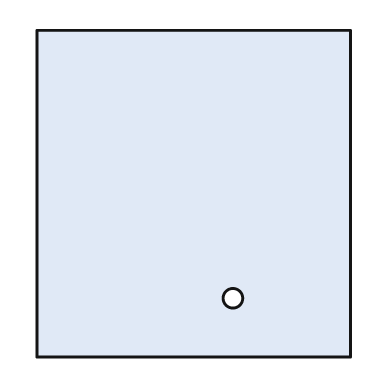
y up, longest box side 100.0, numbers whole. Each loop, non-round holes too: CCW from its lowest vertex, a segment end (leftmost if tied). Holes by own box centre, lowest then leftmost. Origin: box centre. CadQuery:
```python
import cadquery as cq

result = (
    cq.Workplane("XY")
    .moveTo(-48.0, -50.0)
    .lineTo(48.0, -50.0)
    .lineTo(48.0, 50.0)
    .lineTo(-48.0, 50.0)
    .close()
    .moveTo(12.0, -32.0)
    .circle(3.0)
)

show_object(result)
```